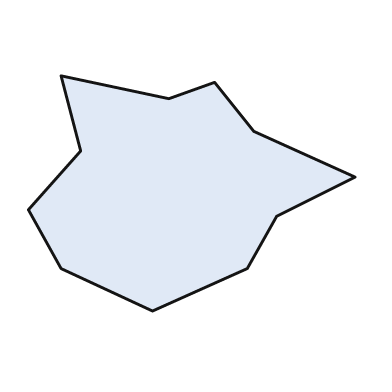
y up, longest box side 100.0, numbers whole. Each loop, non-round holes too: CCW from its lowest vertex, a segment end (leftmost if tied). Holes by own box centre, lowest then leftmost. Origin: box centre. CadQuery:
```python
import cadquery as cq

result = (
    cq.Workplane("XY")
    .moveTo(-12.0, -36.0)
    .lineTo(17.0, -23.0)
    .lineTo(26.0, -7.0)
    .lineTo(50.0, 5.0)
    .lineTo(19.0, 19.0)
    .lineTo(7.0, 34.0)
    .lineTo(-7.0, 29.0)
    .lineTo(-40.0, 36.0)
    .lineTo(-34.0, 13.0)
    .lineTo(-50.0, -5.0)
    .lineTo(-40.0, -23.0)
    .close()
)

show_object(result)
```